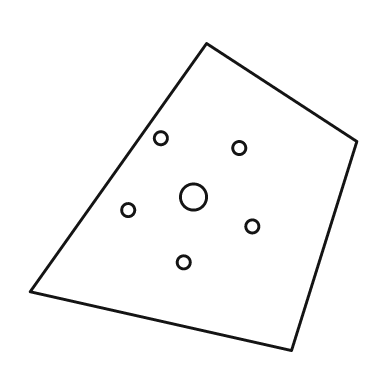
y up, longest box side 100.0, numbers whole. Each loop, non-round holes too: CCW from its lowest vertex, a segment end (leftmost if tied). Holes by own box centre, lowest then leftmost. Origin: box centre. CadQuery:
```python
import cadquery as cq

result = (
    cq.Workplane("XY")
    .moveTo(30.0, -47.0)
    .lineTo(50.0, 17.0)
    .lineTo(4.0, 47.0)
    .lineTo(-50.0, -29.0)
    .close()
    .moveTo(-3.0, -20.0)
    .circle(2.0)
    .moveTo(18.0, -9.0)
    .circle(2.0)
    .moveTo(-20.0, -4.0)
    .circle(2.0)
    .moveTo(0.0, 0.0)
    .circle(4.0)
    .moveTo(14.0, 15.0)
    .circle(2.0)
    .moveTo(-10.0, 18.0)
    .circle(2.0)
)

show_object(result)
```